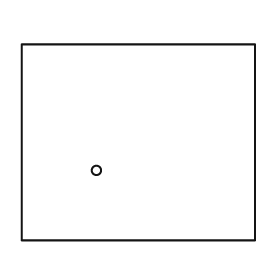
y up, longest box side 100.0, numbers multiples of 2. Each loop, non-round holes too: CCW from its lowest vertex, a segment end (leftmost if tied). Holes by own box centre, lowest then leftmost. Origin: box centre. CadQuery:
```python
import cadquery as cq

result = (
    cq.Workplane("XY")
    .moveTo(-50.0, -42.0)
    .lineTo(50.0, -42.0)
    .lineTo(50.0, 42.0)
    .lineTo(-50.0, 42.0)
    .close()
    .moveTo(-18.0, -12.0)
    .circle(2.0)
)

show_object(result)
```